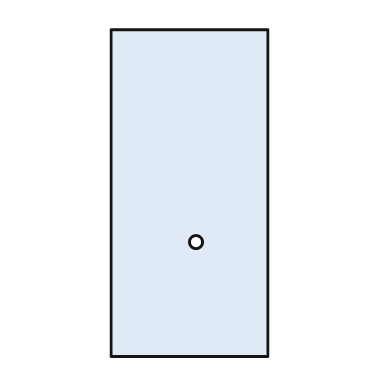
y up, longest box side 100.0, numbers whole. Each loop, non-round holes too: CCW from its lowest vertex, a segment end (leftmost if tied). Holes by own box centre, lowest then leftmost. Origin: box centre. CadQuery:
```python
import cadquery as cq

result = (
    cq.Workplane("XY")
    .moveTo(-24.0, -50.0)
    .lineTo(24.0, -50.0)
    .lineTo(24.0, 50.0)
    .lineTo(-24.0, 50.0)
    .close()
    .moveTo(2.0, -15.0)
    .circle(2.0)
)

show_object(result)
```